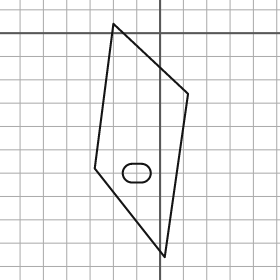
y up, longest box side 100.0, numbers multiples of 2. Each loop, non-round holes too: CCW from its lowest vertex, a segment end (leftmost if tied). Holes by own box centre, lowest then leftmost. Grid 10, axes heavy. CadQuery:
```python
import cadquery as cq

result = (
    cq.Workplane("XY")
    .moveTo(2.0, -96.0)
    .lineTo(12.0, -26.0)
    .lineTo(-20.0, 4.0)
    .lineTo(-28.0, -58.0)
    .close()
    .moveTo(-12.0, -64.0)
    .lineTo(-8.0, -64.0)
    .threePointArc((-4.0, -60.0), (-8.0, -56.0))
    .lineTo(-12.0, -56.0)
    .threePointArc((-16.0, -60.0), (-12.0, -64.0))
    .close()
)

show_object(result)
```